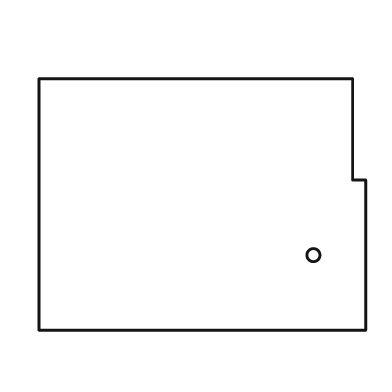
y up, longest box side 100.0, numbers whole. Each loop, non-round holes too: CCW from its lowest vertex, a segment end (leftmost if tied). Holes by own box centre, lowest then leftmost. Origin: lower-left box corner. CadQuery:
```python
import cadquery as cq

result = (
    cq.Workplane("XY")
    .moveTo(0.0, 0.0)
    .lineTo(100.0, 0.0)
    .lineTo(100.0, 46.0)
    .lineTo(96.0, 46.0)
    .lineTo(96.0, 77.0)
    .lineTo(0.0, 77.0)
    .close()
    .moveTo(84.0, 23.0)
    .circle(2.0)
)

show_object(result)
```